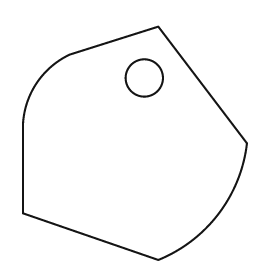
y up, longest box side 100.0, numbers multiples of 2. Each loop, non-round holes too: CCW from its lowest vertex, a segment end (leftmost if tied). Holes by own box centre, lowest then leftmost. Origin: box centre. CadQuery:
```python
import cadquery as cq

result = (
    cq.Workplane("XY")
    .moveTo(10.0, -50.0)
    .threePointArc((36.0, -30.0), (48.0, 0.0))
    .lineTo(10.0, 50.0)
    .lineTo(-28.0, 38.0)
    .threePointArc((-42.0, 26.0), (-48.0, 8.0))
    .lineTo(-48.0, -30.0)
    .close()
    .moveTo(4.0, 28.0)
    .circle(8.0)
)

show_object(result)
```